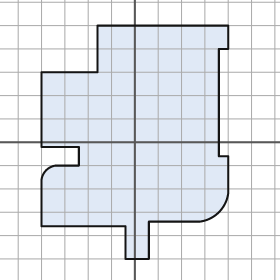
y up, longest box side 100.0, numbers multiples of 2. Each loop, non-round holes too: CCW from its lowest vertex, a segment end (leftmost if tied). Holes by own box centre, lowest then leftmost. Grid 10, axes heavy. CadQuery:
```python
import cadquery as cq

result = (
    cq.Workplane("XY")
    .moveTo(-4.0, -50.0)
    .lineTo(6.0, -50.0)
    .lineTo(6.0, -34.0)
    .lineTo(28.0, -34.0)
    .threePointArc((36.0, -30.0), (40.0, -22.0))
    .lineTo(40.0, -6.0)
    .lineTo(36.0, -6.0)
    .lineTo(36.0, 40.0)
    .lineTo(40.0, 40.0)
    .lineTo(40.0, 50.0)
    .lineTo(-16.0, 50.0)
    .lineTo(-16.0, 30.0)
    .lineTo(-40.0, 30.0)
    .lineTo(-40.0, -2.0)
    .lineTo(-24.0, -2.0)
    .lineTo(-24.0, -10.0)
    .lineTo(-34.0, -10.0)
    .threePointArc((-38.0, -12.0), (-40.0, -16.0))
    .lineTo(-40.0, -36.0)
    .lineTo(-4.0, -36.0)
    .close()
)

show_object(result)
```